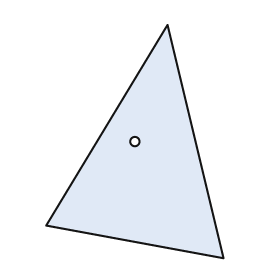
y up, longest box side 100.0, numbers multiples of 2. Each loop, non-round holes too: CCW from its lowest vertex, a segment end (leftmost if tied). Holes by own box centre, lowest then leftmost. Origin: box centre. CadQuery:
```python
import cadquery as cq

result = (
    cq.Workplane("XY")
    .moveTo(38.0, -50.0)
    .lineTo(14.0, 50.0)
    .lineTo(-38.0, -36.0)
    .close()
    .moveTo(0.0, 0.0)
    .circle(2.0)
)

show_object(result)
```